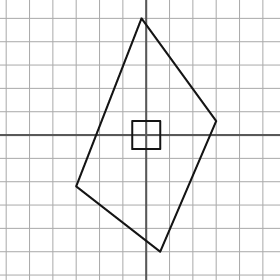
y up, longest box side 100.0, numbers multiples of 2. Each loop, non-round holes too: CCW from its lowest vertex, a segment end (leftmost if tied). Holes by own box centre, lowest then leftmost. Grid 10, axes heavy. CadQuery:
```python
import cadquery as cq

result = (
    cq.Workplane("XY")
    .moveTo(6.0, -50.0)
    .lineTo(30.0, 6.0)
    .lineTo(-2.0, 50.0)
    .lineTo(-30.0, -22.0)
    .close()
    .moveTo(-6.0, -6.0)
    .lineTo(6.0, -6.0)
    .lineTo(6.0, 6.0)
    .lineTo(-6.0, 6.0)
    .close()
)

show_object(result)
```